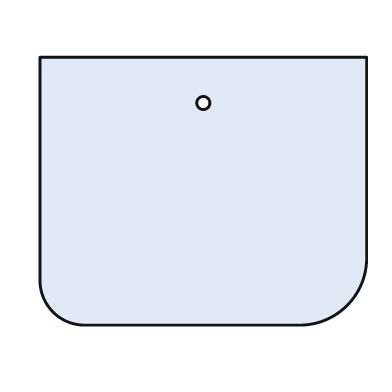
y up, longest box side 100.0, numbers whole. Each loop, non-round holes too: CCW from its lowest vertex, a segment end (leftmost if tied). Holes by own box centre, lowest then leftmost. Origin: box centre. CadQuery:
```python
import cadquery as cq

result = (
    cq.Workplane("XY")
    .moveTo(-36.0, -41.0)
    .lineTo(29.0, -41.0)
    .threePointArc((44.0, -35.0), (50.0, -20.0))
    .lineTo(50.0, 41.0)
    .lineTo(-50.0, 41.0)
    .lineTo(-50.0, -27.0)
    .threePointArc((-46.0, -37.0), (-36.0, -41.0))
    .close()
    .moveTo(0.0, 27.0)
    .circle(2.0)
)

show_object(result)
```